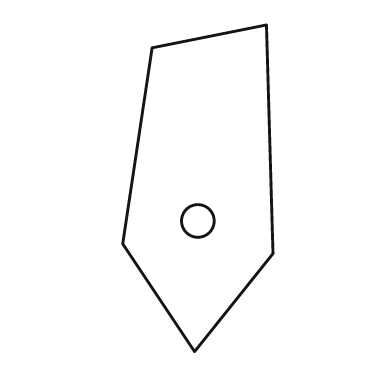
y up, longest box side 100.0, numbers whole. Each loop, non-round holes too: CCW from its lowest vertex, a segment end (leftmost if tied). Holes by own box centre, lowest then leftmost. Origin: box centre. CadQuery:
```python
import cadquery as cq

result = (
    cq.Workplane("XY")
    .moveTo(-1.0, -50.0)
    .lineTo(23.0, -20.0)
    .lineTo(21.0, 50.0)
    .lineTo(-14.0, 43.0)
    .lineTo(-23.0, -17.0)
    .close()
    .moveTo(0.0, -10.0)
    .circle(5.0)
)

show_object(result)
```